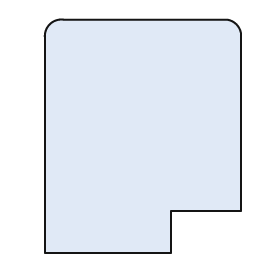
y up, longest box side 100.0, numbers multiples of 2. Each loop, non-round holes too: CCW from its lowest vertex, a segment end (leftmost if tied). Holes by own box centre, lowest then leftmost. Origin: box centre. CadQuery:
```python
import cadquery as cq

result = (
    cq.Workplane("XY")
    .moveTo(-42.0, -50.0)
    .lineTo(12.0, -50.0)
    .lineTo(12.0, -32.0)
    .lineTo(42.0, -32.0)
    .lineTo(42.0, 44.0)
    .threePointArc((40.0, 48.0), (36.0, 50.0))
    .lineTo(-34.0, 50.0)
    .threePointArc((-40.0, 48.0), (-42.0, 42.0))
    .close()
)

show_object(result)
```